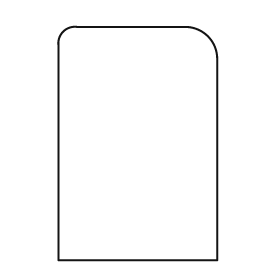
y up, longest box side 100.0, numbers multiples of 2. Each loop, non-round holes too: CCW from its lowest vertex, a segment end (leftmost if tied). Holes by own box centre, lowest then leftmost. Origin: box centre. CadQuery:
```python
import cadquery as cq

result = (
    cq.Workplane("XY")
    .moveTo(-34.0, -50.0)
    .lineTo(34.0, -50.0)
    .lineTo(34.0, 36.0)
    .threePointArc((30.0, 46.0), (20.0, 50.0))
    .lineTo(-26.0, 50.0)
    .threePointArc((-32.0, 48.0), (-34.0, 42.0))
    .close()
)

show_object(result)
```